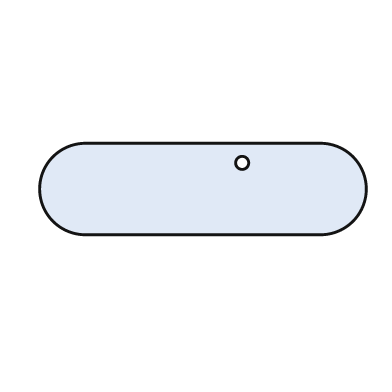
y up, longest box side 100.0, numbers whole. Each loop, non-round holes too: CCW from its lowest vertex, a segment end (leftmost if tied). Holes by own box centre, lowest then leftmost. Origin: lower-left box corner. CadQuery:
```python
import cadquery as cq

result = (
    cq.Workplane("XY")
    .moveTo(14.0, 0.0)
    .lineTo(86.0, 0.0)
    .threePointArc((100.0, 14.0), (86.0, 28.0))
    .lineTo(14.0, 28.0)
    .threePointArc((0.0, 14.0), (14.0, 0.0))
    .close()
    .moveTo(62.0, 22.0)
    .circle(2.0)
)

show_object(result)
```